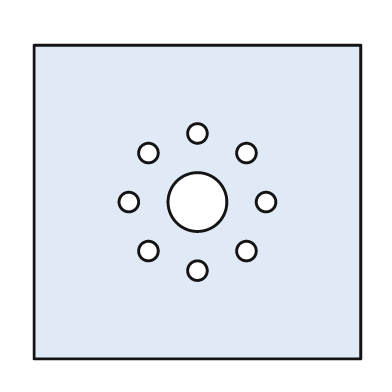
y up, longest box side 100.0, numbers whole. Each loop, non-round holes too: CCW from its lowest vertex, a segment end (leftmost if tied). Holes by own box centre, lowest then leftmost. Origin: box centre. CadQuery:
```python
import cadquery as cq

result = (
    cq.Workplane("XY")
    .moveTo(-50.0, -48.0)
    .lineTo(50.0, -48.0)
    .lineTo(50.0, 48.0)
    .lineTo(-50.0, 48.0)
    .close()
    .moveTo(0.0, -21.0)
    .circle(3.0)
    .moveTo(-15.0, -15.0)
    .circle(3.0)
    .moveTo(15.0, -15.0)
    .circle(3.0)
    .moveTo(-21.0, 0.0)
    .circle(3.0)
    .moveTo(0.0, 0.0)
    .circle(9.0)
    .moveTo(21.0, 0.0)
    .circle(3.0)
    .moveTo(-15.0, 15.0)
    .circle(3.0)
    .moveTo(15.0, 15.0)
    .circle(3.0)
    .moveTo(0.0, 21.0)
    .circle(3.0)
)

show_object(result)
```